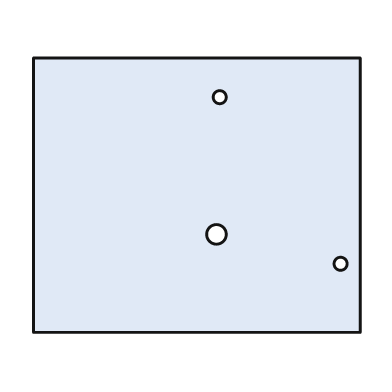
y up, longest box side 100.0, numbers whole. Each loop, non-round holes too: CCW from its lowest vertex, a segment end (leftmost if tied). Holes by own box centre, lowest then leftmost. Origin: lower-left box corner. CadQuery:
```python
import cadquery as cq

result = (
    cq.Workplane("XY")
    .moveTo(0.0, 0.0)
    .lineTo(100.0, 0.0)
    .lineTo(100.0, 84.0)
    .lineTo(0.0, 84.0)
    .close()
    .moveTo(94.0, 21.0)
    .circle(2.0)
    .moveTo(56.0, 30.0)
    .circle(3.0)
    .moveTo(57.0, 72.0)
    .circle(2.0)
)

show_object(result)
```